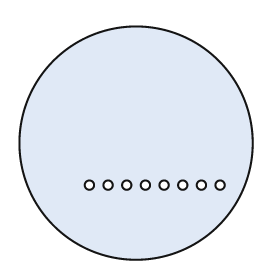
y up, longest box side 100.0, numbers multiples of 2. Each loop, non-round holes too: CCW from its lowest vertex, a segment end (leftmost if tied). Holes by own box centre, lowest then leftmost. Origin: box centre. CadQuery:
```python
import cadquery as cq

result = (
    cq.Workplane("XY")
    .moveTo(0.0, 0.0)
    .circle(50.0)
    .moveTo(-20.0, -18.0)
    .circle(2.0)
    .moveTo(-12.0, -18.0)
    .circle(2.0)
    .moveTo(-4.0, -18.0)
    .circle(2.0)
    .moveTo(4.0, -18.0)
    .circle(2.0)
    .moveTo(12.0, -18.0)
    .circle(2.0)
    .moveTo(20.0, -18.0)
    .circle(2.0)
    .moveTo(28.0, -18.0)
    .circle(2.0)
    .moveTo(36.0, -18.0)
    .circle(2.0)
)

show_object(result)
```